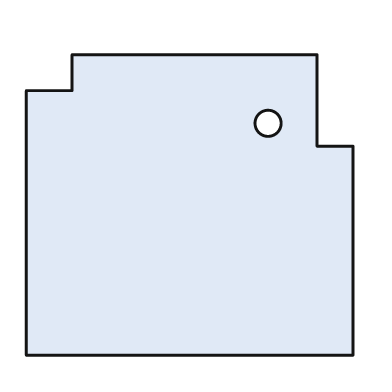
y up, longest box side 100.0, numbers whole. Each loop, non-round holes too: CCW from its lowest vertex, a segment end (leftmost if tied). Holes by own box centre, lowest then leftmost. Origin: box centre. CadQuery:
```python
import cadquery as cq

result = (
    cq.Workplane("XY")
    .moveTo(-50.0, -46.0)
    .lineTo(50.0, -46.0)
    .lineTo(50.0, 18.0)
    .lineTo(39.0, 18.0)
    .lineTo(39.0, 46.0)
    .lineTo(-36.0, 46.0)
    .lineTo(-36.0, 35.0)
    .lineTo(-50.0, 35.0)
    .close()
    .moveTo(24.0, 25.0)
    .circle(4.0)
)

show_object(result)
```